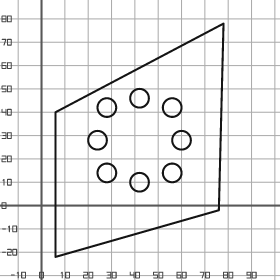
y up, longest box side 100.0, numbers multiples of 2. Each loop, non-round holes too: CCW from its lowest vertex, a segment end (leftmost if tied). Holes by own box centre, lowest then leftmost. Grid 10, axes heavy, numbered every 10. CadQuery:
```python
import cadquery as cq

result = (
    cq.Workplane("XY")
    .moveTo(6.0, -22.0)
    .lineTo(76.0, -2.0)
    .lineTo(78.0, 78.0)
    .lineTo(6.0, 40.0)
    .close()
    .moveTo(42.0, 10.0)
    .circle(4.0)
    .moveTo(28.0, 14.0)
    .circle(4.0)
    .moveTo(56.0, 14.0)
    .circle(4.0)
    .moveTo(24.0, 28.0)
    .circle(4.0)
    .moveTo(60.0, 28.0)
    .circle(4.0)
    .moveTo(28.0, 42.0)
    .circle(4.0)
    .moveTo(56.0, 42.0)
    .circle(4.0)
    .moveTo(42.0, 46.0)
    .circle(4.0)
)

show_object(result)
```